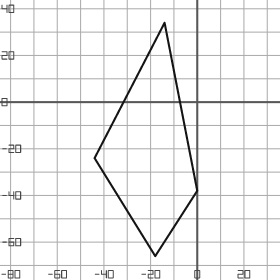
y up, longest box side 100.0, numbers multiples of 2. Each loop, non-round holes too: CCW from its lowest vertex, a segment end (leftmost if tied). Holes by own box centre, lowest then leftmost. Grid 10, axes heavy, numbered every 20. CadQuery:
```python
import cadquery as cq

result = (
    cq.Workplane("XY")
    .moveTo(-18.0, -66.0)
    .lineTo(0.0, -38.0)
    .lineTo(-14.0, 34.0)
    .lineTo(-44.0, -24.0)
    .close()
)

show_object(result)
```